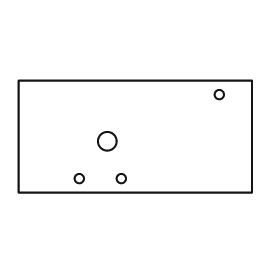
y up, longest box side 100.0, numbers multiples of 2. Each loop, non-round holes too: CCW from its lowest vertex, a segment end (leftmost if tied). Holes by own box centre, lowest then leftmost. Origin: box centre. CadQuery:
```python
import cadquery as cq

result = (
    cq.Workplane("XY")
    .moveTo(-50.0, -24.0)
    .lineTo(50.0, -24.0)
    .lineTo(50.0, 24.0)
    .lineTo(-50.0, 24.0)
    .close()
    .moveTo(-24.0, -18.0)
    .circle(2.0)
    .moveTo(-6.0, -18.0)
    .circle(2.0)
    .moveTo(-12.0, -2.0)
    .circle(4.0)
    .moveTo(36.0, 18.0)
    .circle(2.0)
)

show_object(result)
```